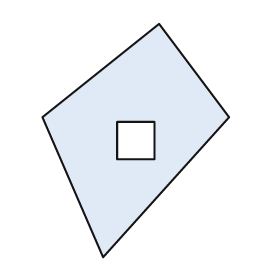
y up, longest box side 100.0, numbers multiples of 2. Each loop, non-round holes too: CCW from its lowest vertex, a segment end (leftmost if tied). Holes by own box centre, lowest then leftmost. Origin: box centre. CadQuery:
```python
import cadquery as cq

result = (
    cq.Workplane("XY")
    .moveTo(-14.0, -50.0)
    .lineTo(40.0, 10.0)
    .lineTo(10.0, 50.0)
    .lineTo(-40.0, 10.0)
    .close()
    .moveTo(-8.0, -8.0)
    .lineTo(8.0, -8.0)
    .lineTo(8.0, 8.0)
    .lineTo(-8.0, 8.0)
    .close()
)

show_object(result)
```